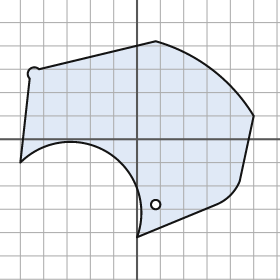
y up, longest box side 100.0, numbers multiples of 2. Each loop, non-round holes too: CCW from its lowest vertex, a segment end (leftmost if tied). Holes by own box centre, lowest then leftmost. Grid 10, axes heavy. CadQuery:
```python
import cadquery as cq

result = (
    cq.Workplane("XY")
    .moveTo(0.0, -42.0)
    .lineTo(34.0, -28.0)
    .threePointArc((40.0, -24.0), (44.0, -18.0))
    .lineTo(50.0, 10.0)
    .threePointArc((32.0, 30.0), (8.0, 42.0))
    .lineTo(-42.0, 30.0)
    .threePointArc((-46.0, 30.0), (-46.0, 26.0))
    .lineTo(-50.0, -10.0)
    .threePointArc((-12.0, -6.0), (0.0, -42.0))
    .close()
    .moveTo(8.0, -28.0)
    .circle(2.0)
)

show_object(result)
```